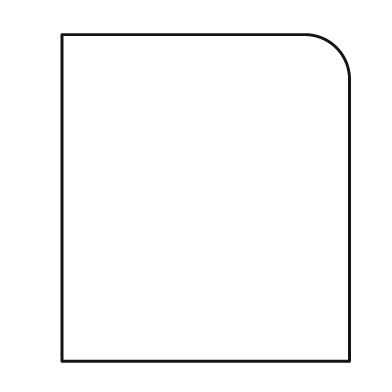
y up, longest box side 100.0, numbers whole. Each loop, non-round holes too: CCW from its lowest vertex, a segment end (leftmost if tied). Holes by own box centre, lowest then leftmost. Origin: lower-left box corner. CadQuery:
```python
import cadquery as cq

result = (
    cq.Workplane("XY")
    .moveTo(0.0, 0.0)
    .lineTo(88.0, 0.0)
    .lineTo(88.0, 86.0)
    .threePointArc((84.0, 96.0), (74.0, 100.0))
    .lineTo(0.0, 100.0)
    .close()
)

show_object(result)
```